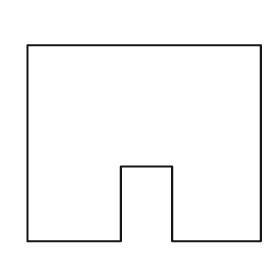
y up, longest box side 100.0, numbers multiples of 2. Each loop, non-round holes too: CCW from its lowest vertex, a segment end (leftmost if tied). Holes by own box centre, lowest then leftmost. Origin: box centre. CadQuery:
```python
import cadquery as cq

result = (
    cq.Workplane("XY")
    .moveTo(-50.0, -42.0)
    .lineTo(-10.0, -42.0)
    .lineTo(-10.0, -10.0)
    .lineTo(12.0, -10.0)
    .lineTo(12.0, -42.0)
    .lineTo(50.0, -42.0)
    .lineTo(50.0, 42.0)
    .lineTo(-50.0, 42.0)
    .close()
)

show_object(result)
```